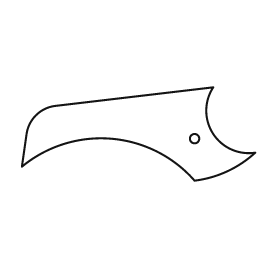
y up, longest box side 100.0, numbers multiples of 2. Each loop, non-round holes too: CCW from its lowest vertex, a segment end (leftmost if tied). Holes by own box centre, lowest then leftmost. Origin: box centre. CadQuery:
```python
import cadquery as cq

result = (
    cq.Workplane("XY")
    .moveTo(24.0, -20.0)
    .threePointArc((38.0, -16.0), (50.0, -8.0))
    .threePointArc((32.0, 0.0), (32.0, 20.0))
    .lineTo(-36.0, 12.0)
    .threePointArc((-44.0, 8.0), (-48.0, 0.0))
    .lineTo(-50.0, -14.0)
    .threePointArc((-12.0, -2.0), (24.0, -20.0))
    .close()
    .moveTo(24.0, -2.0)
    .circle(2.0)
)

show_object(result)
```